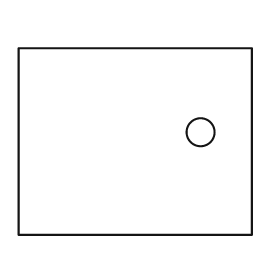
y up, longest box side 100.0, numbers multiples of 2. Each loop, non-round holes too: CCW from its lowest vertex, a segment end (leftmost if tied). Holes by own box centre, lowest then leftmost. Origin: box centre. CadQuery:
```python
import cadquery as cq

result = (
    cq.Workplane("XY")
    .moveTo(-50.0, -40.0)
    .lineTo(50.0, -40.0)
    .lineTo(50.0, 40.0)
    .lineTo(-50.0, 40.0)
    .close()
    .moveTo(28.0, 4.0)
    .circle(6.0)
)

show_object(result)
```